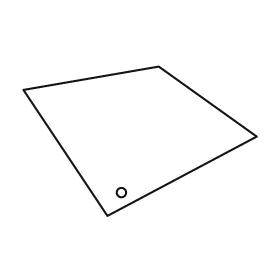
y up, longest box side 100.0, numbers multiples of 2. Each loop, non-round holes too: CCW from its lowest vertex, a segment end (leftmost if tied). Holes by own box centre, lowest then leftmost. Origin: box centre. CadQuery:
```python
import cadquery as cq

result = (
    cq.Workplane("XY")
    .moveTo(-14.0, -32.0)
    .lineTo(50.0, 2.0)
    .lineTo(8.0, 32.0)
    .lineTo(-50.0, 22.0)
    .close()
    .moveTo(-8.0, -22.0)
    .circle(2.0)
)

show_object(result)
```